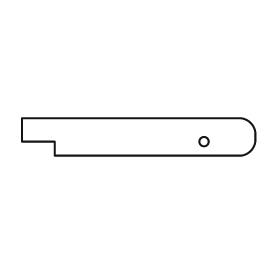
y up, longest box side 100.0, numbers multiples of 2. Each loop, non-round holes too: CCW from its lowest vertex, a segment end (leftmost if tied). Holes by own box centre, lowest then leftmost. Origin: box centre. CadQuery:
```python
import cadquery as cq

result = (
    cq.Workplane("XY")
    .moveTo(-36.0, -8.0)
    .lineTo(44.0, -8.0)
    .threePointArc((48.0, -6.0), (50.0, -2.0))
    .lineTo(50.0, 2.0)
    .threePointArc((48.0, 6.0), (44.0, 8.0))
    .lineTo(-50.0, 8.0)
    .lineTo(-50.0, -2.0)
    .lineTo(-36.0, -2.0)
    .close()
    .moveTo(28.0, -2.0)
    .circle(2.0)
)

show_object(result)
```